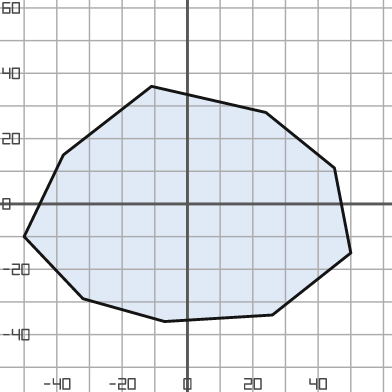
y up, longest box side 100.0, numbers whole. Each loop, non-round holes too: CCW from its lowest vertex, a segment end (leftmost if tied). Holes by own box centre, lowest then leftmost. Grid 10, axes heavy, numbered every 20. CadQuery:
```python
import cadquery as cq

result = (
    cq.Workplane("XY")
    .moveTo(-7.0, -36.0)
    .lineTo(26.0, -34.0)
    .lineTo(50.0, -15.0)
    .lineTo(45.0, 11.0)
    .lineTo(24.0, 28.0)
    .lineTo(-11.0, 36.0)
    .lineTo(-38.0, 15.0)
    .lineTo(-50.0, -10.0)
    .lineTo(-32.0, -29.0)
    .close()
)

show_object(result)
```